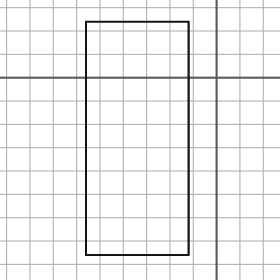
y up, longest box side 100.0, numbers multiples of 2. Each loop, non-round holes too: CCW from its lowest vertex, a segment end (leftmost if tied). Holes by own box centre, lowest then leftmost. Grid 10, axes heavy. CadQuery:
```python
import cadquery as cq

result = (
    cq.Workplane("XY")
    .moveTo(-56.0, -76.0)
    .lineTo(-12.0, -76.0)
    .lineTo(-12.0, 24.0)
    .lineTo(-56.0, 24.0)
    .close()
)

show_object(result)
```